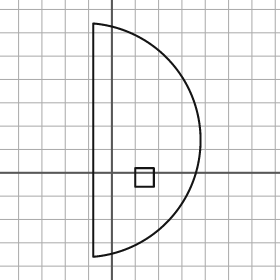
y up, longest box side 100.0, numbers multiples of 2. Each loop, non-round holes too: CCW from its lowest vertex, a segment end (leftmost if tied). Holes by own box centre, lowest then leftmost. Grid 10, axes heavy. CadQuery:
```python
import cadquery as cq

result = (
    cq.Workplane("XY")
    .moveTo(-8.0, -36.0)
    .threePointArc((38.0, 14.0), (-8.0, 64.0))
    .close()
    .moveTo(10.0, -6.0)
    .lineTo(18.0, -6.0)
    .lineTo(18.0, 2.0)
    .lineTo(10.0, 2.0)
    .close()
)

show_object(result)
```